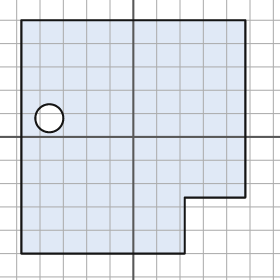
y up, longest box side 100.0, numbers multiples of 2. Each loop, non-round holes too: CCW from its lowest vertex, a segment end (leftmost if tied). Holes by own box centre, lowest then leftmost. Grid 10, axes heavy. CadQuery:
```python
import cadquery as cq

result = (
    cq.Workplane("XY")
    .moveTo(-48.0, -50.0)
    .lineTo(22.0, -50.0)
    .lineTo(22.0, -26.0)
    .lineTo(48.0, -26.0)
    .lineTo(48.0, 50.0)
    .lineTo(-48.0, 50.0)
    .close()
    .moveTo(-36.0, 8.0)
    .circle(6.0)
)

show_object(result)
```